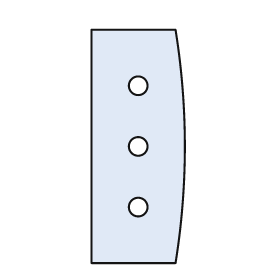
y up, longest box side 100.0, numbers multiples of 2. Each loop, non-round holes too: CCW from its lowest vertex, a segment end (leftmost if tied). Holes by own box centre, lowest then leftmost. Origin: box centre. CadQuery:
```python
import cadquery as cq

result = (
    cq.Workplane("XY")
    .moveTo(-20.0, -50.0)
    .lineTo(16.0, -50.0)
    .threePointArc((20.0, 0.0), (16.0, 50.0))
    .lineTo(-20.0, 50.0)
    .close()
    .moveTo(0.0, -26.0)
    .circle(4.0)
    .moveTo(0.0, 0.0)
    .circle(4.0)
    .moveTo(0.0, 26.0)
    .circle(4.0)
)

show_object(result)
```